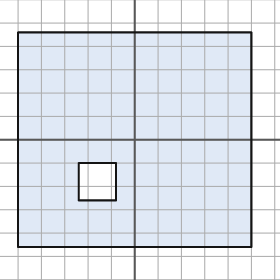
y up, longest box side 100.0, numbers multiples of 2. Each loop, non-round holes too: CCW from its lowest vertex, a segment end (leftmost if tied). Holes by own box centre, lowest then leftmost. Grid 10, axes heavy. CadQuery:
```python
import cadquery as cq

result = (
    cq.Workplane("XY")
    .moveTo(-50.0, -46.0)
    .lineTo(50.0, -46.0)
    .lineTo(50.0, 46.0)
    .lineTo(-50.0, 46.0)
    .close()
    .moveTo(-24.0, -26.0)
    .lineTo(-8.0, -26.0)
    .lineTo(-8.0, -10.0)
    .lineTo(-24.0, -10.0)
    .close()
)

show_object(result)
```